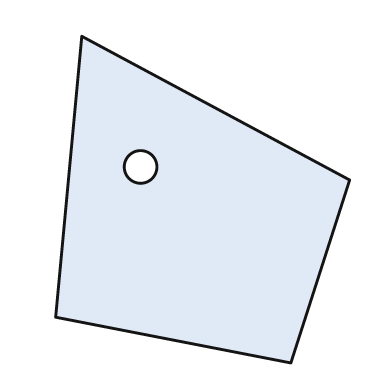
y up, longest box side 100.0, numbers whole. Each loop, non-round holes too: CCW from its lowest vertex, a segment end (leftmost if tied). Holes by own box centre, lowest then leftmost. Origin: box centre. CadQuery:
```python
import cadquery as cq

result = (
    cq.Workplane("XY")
    .moveTo(27.0, -50.0)
    .lineTo(45.0, 6.0)
    .lineTo(-37.0, 50.0)
    .lineTo(-45.0, -36.0)
    .close()
    .moveTo(-19.0, 10.0)
    .circle(5.0)
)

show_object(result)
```